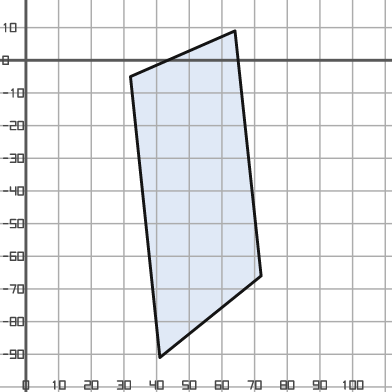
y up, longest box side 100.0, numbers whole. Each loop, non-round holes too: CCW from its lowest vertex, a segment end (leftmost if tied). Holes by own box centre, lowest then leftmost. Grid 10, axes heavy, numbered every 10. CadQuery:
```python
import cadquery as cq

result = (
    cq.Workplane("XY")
    .moveTo(41.0, -91.0)
    .lineTo(72.0, -66.0)
    .lineTo(64.0, 9.0)
    .lineTo(32.0, -5.0)
    .close()
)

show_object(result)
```